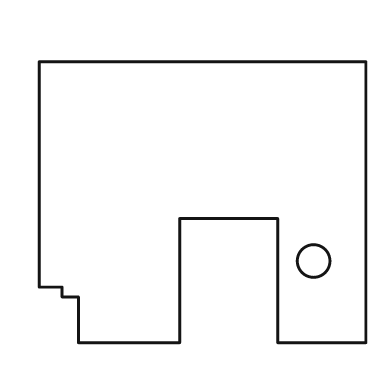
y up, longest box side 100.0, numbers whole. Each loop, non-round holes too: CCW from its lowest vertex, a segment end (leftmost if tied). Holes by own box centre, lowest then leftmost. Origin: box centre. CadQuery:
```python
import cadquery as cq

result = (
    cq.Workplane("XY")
    .moveTo(-38.0, -43.0)
    .lineTo(-7.0, -43.0)
    .lineTo(-7.0, -5.0)
    .lineTo(23.0, -5.0)
    .lineTo(23.0, -43.0)
    .lineTo(50.0, -43.0)
    .lineTo(50.0, 43.0)
    .lineTo(-50.0, 43.0)
    .lineTo(-50.0, -26.0)
    .lineTo(-43.0, -26.0)
    .lineTo(-43.0, -29.0)
    .lineTo(-38.0, -29.0)
    .close()
    .moveTo(34.0, -18.0)
    .circle(5.0)
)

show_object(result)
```